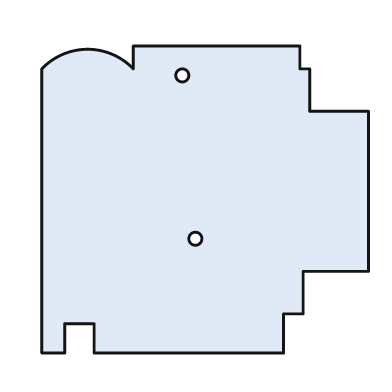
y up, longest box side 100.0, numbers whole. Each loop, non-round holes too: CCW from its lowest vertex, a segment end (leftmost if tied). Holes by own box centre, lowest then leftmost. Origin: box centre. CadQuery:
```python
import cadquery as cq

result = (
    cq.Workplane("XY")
    .moveTo(-50.0, -47.0)
    .lineTo(-43.0, -47.0)
    .lineTo(-43.0, -38.0)
    .lineTo(-34.0, -38.0)
    .lineTo(-34.0, -47.0)
    .lineTo(24.0, -47.0)
    .lineTo(24.0, -35.0)
    .lineTo(30.0, -35.0)
    .lineTo(30.0, -22.0)
    .lineTo(50.0, -22.0)
    .lineTo(50.0, 27.0)
    .lineTo(32.0, 27.0)
    .lineTo(32.0, 40.0)
    .lineTo(29.0, 40.0)
    .lineTo(29.0, 47.0)
    .lineTo(-22.0, 47.0)
    .lineTo(-22.0, 40.0)
    .threePointArc((-36.0, 46.0), (-50.0, 40.0))
    .close()
    .moveTo(-3.0, -12.0)
    .circle(2.0)
    .moveTo(-7.0, 38.0)
    .circle(2.0)
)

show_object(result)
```